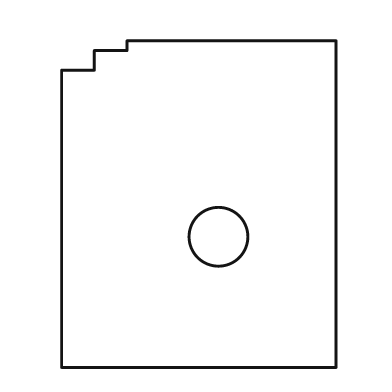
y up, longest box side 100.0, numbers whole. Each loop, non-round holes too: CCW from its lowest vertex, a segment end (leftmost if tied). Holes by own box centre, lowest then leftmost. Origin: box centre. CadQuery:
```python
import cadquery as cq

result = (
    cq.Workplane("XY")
    .moveTo(-42.0, -50.0)
    .lineTo(42.0, -50.0)
    .lineTo(42.0, 50.0)
    .lineTo(-22.0, 50.0)
    .lineTo(-22.0, 47.0)
    .lineTo(-32.0, 47.0)
    .lineTo(-32.0, 41.0)
    .lineTo(-42.0, 41.0)
    .close()
    .moveTo(6.0, -10.0)
    .circle(9.0)
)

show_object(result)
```